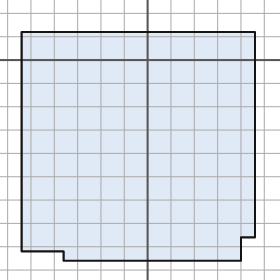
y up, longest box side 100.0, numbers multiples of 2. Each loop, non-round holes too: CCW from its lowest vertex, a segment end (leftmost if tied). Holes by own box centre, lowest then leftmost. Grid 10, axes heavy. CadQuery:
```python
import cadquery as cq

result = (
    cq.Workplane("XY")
    .moveTo(-36.0, -86.0)
    .lineTo(40.0, -86.0)
    .lineTo(40.0, -76.0)
    .lineTo(46.0, -76.0)
    .lineTo(46.0, 12.0)
    .lineTo(-54.0, 12.0)
    .lineTo(-54.0, -82.0)
    .lineTo(-36.0, -82.0)
    .close()
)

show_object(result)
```